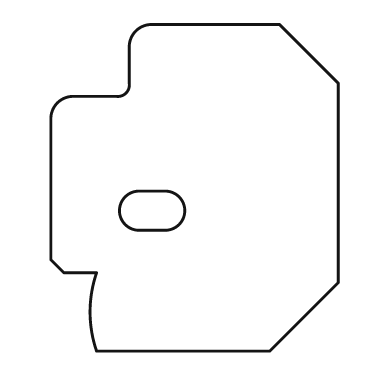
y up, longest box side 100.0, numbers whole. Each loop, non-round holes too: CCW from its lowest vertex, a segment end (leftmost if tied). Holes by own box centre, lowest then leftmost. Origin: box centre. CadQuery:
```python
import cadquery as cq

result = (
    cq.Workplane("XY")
    .moveTo(-30.0, -50.0)
    .lineTo(23.0, -50.0)
    .lineTo(44.0, -29.0)
    .lineTo(44.0, 32.0)
    .lineTo(26.0, 50.0)
    .lineTo(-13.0, 50.0)
    .threePointArc((-18.0, 48.0), (-20.0, 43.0))
    .lineTo(-20.0, 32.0)
    .threePointArc((-21.0, 29.0), (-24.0, 28.0))
    .lineTo(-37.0, 28.0)
    .threePointArc((-42.0, 26.0), (-44.0, 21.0))
    .lineTo(-44.0, -22.0)
    .lineTo(-40.0, -26.0)
    .lineTo(-30.0, -26.0)
    .threePointArc((-32.0, -38.0), (-30.0, -50.0))
    .close()
    .moveTo(-17.0, -13.0)
    .lineTo(-9.0, -13.0)
    .threePointArc((-3.0, -7.0), (-9.0, -1.0))
    .lineTo(-17.0, -1.0)
    .threePointArc((-23.0, -7.0), (-17.0, -13.0))
    .close()
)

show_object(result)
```